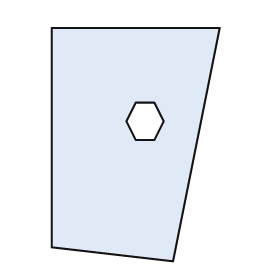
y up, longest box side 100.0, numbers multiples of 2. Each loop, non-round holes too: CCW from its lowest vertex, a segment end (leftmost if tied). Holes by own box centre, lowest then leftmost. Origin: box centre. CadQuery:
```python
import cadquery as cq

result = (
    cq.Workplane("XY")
    .moveTo(16.0, -50.0)
    .lineTo(36.0, 50.0)
    .lineTo(-36.0, 50.0)
    .lineTo(-36.0, -44.0)
    .close()
    .moveTo(0.0, 2.0)
    .lineTo(8.0, 2.0)
    .lineTo(12.0, 10.0)
    .lineTo(8.0, 18.0)
    .lineTo(0.0, 18.0)
    .lineTo(-4.0, 10.0)
    .close()
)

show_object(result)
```